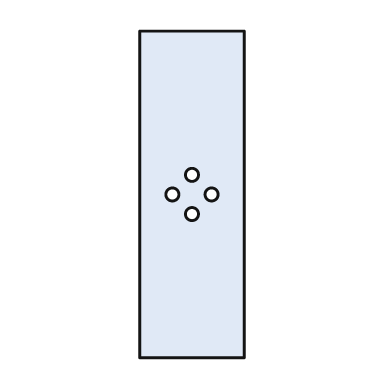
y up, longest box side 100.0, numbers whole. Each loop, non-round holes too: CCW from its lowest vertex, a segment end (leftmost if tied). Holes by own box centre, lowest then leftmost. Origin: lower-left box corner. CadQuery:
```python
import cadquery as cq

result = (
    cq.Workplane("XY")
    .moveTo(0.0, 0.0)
    .lineTo(32.0, 0.0)
    .lineTo(32.0, 100.0)
    .lineTo(0.0, 100.0)
    .close()
    .moveTo(16.0, 44.0)
    .circle(2.0)
    .moveTo(10.0, 50.0)
    .circle(2.0)
    .moveTo(22.0, 50.0)
    .circle(2.0)
    .moveTo(16.0, 56.0)
    .circle(2.0)
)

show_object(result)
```